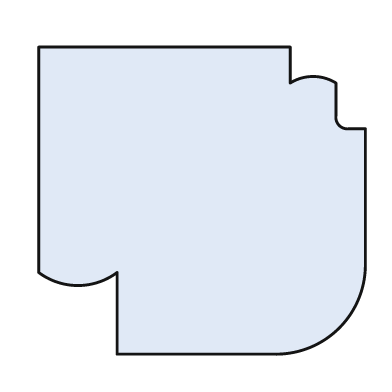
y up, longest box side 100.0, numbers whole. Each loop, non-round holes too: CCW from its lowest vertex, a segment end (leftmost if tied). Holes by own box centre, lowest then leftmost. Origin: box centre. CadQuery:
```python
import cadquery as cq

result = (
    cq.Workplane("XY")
    .moveTo(-26.0, -47.0)
    .lineTo(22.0, -47.0)
    .threePointArc((42.0, -39.0), (50.0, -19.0))
    .lineTo(50.0, 22.0)
    .lineTo(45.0, 22.0)
    .threePointArc((42.0, 23.0), (41.0, 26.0))
    .lineTo(41.0, 36.0)
    .threePointArc((34.0, 38.0), (27.0, 36.0))
    .lineTo(27.0, 47.0)
    .lineTo(-50.0, 47.0)
    .lineTo(-50.0, -22.0)
    .threePointArc((-38.0, -26.0), (-26.0, -22.0))
    .close()
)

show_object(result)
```